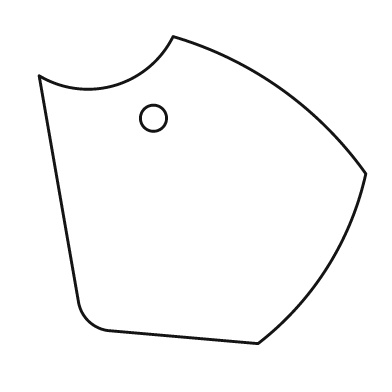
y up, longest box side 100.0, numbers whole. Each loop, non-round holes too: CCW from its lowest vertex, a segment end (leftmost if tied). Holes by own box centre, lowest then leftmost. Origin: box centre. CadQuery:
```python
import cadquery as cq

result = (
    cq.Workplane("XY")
    .moveTo(17.0, -47.0)
    .threePointArc((38.0, -24.0), (50.0, 5.0))
    .threePointArc((24.0, 31.0), (-9.0, 47.0))
    .threePointArc((-27.0, 32.0), (-50.0, 35.0))
    .lineTo(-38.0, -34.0)
    .threePointArc((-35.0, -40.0), (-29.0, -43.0))
    .close()
    .moveTo(-15.0, 22.0)
    .circle(4.0)
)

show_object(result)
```